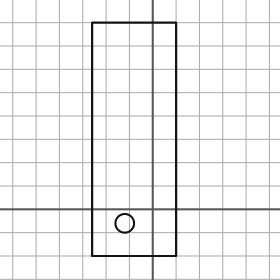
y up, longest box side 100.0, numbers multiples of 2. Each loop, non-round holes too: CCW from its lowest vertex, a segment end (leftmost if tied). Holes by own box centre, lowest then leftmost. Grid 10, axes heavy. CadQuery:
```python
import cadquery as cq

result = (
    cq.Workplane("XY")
    .moveTo(-26.0, -20.0)
    .lineTo(10.0, -20.0)
    .lineTo(10.0, 80.0)
    .lineTo(-26.0, 80.0)
    .close()
    .moveTo(-12.0, -6.0)
    .circle(4.0)
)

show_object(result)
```